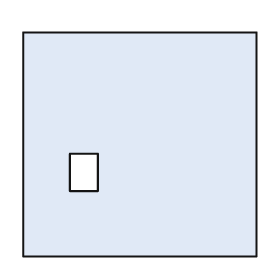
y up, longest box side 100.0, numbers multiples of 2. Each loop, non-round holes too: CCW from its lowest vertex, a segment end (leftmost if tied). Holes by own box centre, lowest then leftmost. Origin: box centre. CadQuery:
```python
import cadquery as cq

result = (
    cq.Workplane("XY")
    .moveTo(-50.0, -48.0)
    .lineTo(50.0, -48.0)
    .lineTo(50.0, 48.0)
    .lineTo(-50.0, 48.0)
    .close()
    .moveTo(-30.0, -20.0)
    .lineTo(-18.0, -20.0)
    .lineTo(-18.0, -4.0)
    .lineTo(-30.0, -4.0)
    .close()
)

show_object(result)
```